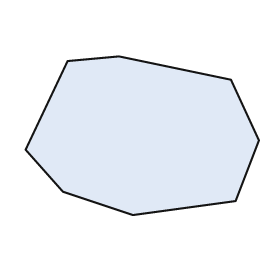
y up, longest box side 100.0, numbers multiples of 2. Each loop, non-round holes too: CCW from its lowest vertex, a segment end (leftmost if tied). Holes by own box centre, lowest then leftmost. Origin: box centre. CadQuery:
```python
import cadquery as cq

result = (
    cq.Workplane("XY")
    .moveTo(-4.0, -34.0)
    .lineTo(40.0, -28.0)
    .lineTo(50.0, -2.0)
    .lineTo(38.0, 24.0)
    .lineTo(-10.0, 34.0)
    .lineTo(-32.0, 32.0)
    .lineTo(-50.0, -6.0)
    .lineTo(-34.0, -24.0)
    .close()
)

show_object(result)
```